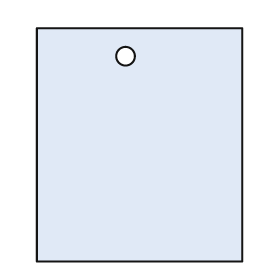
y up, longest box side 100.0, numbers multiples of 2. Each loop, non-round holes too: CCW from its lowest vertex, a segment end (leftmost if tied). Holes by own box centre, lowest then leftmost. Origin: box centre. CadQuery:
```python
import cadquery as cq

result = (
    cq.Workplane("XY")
    .moveTo(-44.0, -50.0)
    .lineTo(44.0, -50.0)
    .lineTo(44.0, 50.0)
    .lineTo(-44.0, 50.0)
    .close()
    .moveTo(-6.0, 38.0)
    .circle(4.0)
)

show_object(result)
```